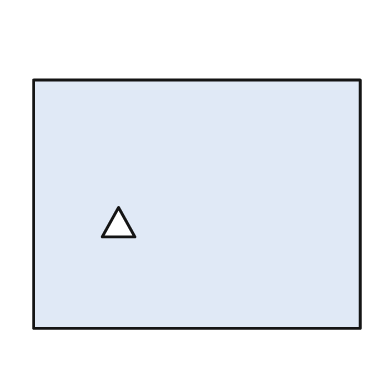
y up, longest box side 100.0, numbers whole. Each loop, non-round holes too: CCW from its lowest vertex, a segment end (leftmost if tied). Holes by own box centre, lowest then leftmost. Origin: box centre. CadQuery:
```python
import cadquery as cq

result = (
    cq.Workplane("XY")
    .moveTo(-50.0, -38.0)
    .lineTo(50.0, -38.0)
    .lineTo(50.0, 38.0)
    .lineTo(-50.0, 38.0)
    .close()
    .moveTo(-29.0, -10.0)
    .lineTo(-19.0, -10.0)
    .lineTo(-24.0, -1.0)
    .close()
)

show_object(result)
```